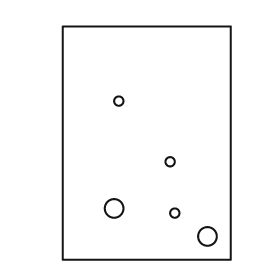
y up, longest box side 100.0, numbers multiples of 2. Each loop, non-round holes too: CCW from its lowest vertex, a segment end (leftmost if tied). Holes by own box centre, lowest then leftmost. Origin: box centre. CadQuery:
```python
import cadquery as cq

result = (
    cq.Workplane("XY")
    .moveTo(-36.0, -50.0)
    .lineTo(36.0, -50.0)
    .lineTo(36.0, 50.0)
    .lineTo(-36.0, 50.0)
    .close()
    .moveTo(26.0, -40.0)
    .circle(4.0)
    .moveTo(12.0, -30.0)
    .circle(2.0)
    .moveTo(-14.0, -28.0)
    .circle(4.0)
    .moveTo(10.0, -8.0)
    .circle(2.0)
    .moveTo(-12.0, 18.0)
    .circle(2.0)
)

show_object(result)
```